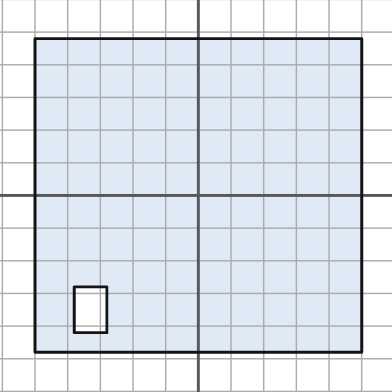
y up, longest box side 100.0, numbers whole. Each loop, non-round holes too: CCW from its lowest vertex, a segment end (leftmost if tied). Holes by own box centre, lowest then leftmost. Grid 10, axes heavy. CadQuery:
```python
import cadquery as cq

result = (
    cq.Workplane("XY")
    .moveTo(-50.0, -48.0)
    .lineTo(50.0, -48.0)
    .lineTo(50.0, 48.0)
    .lineTo(-50.0, 48.0)
    .close()
    .moveTo(-38.0, -42.0)
    .lineTo(-28.0, -42.0)
    .lineTo(-28.0, -28.0)
    .lineTo(-38.0, -28.0)
    .close()
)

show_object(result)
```